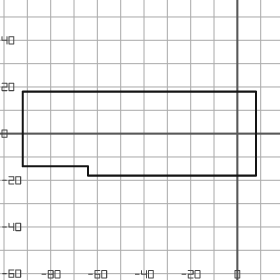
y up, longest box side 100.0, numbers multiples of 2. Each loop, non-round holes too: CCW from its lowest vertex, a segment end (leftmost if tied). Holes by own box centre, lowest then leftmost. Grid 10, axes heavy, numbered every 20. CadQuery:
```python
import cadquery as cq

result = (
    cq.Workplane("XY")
    .moveTo(-64.0, -18.0)
    .lineTo(8.0, -18.0)
    .lineTo(8.0, 18.0)
    .lineTo(-92.0, 18.0)
    .lineTo(-92.0, -14.0)
    .lineTo(-64.0, -14.0)
    .close()
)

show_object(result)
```